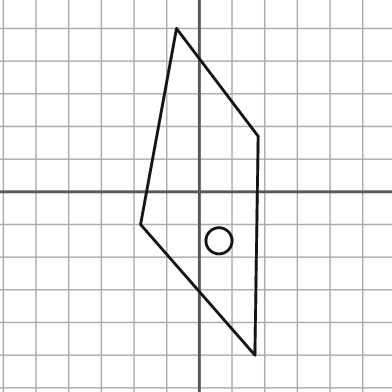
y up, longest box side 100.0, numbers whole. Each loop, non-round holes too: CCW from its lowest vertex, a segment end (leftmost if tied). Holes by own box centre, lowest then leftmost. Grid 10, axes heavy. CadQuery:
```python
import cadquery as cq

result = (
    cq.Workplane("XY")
    .moveTo(17.0, -50.0)
    .lineTo(18.0, 17.0)
    .lineTo(-7.0, 50.0)
    .lineTo(-18.0, -10.0)
    .close()
    .moveTo(6.0, -15.0)
    .circle(4.0)
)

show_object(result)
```